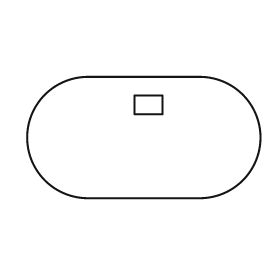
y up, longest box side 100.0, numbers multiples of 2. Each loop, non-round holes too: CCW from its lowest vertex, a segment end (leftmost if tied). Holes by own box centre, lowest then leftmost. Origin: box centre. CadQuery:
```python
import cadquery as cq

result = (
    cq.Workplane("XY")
    .moveTo(-24.0, -26.0)
    .lineTo(24.0, -26.0)
    .threePointArc((50.0, 0.0), (24.0, 26.0))
    .lineTo(-24.0, 26.0)
    .threePointArc((-50.0, 0.0), (-24.0, -26.0))
    .close()
    .moveTo(-4.0, 10.0)
    .lineTo(8.0, 10.0)
    .lineTo(8.0, 18.0)
    .lineTo(-4.0, 18.0)
    .close()
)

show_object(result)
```